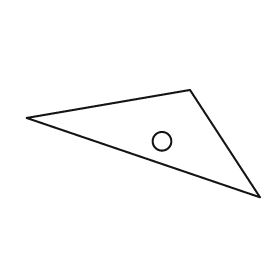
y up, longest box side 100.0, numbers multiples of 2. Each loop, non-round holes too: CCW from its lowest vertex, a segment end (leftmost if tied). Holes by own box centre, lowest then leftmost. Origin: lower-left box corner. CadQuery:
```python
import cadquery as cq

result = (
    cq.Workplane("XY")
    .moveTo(100.0, 0.0)
    .lineTo(70.0, 46.0)
    .lineTo(0.0, 34.0)
    .close()
    .moveTo(58.0, 24.0)
    .circle(4.0)
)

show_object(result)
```